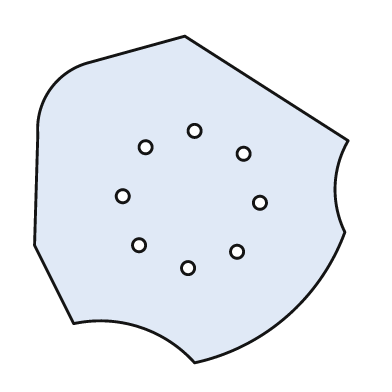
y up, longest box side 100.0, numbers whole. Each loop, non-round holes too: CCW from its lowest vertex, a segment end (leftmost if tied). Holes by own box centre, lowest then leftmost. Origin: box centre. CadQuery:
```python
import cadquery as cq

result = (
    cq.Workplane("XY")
    .moveTo(1.0, -50.0)
    .threePointArc((29.0, -36.0), (47.0, -10.0))
    .threePointArc((44.0, 4.0), (48.0, 18.0))
    .lineTo(-2.0, 50.0)
    .lineTo(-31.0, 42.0)
    .threePointArc((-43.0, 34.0), (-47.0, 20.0))
    .lineTo(-48.0, -14.0)
    .lineTo(-36.0, -38.0)
    .threePointArc((-16.0, -39.0), (1.0, -50.0))
    .close()
    .moveTo(-1.0, -21.0)
    .circle(2.0)
    .moveTo(14.0, -16.0)
    .circle(2.0)
    .moveTo(-16.0, -14.0)
    .circle(2.0)
    .moveTo(21.0, -1.0)
    .circle(2.0)
    .moveTo(-21.0, 1.0)
    .circle(2.0)
    .moveTo(16.0, 14.0)
    .circle(2.0)
    .moveTo(-14.0, 16.0)
    .circle(2.0)
    .moveTo(1.0, 21.0)
    .circle(2.0)
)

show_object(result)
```